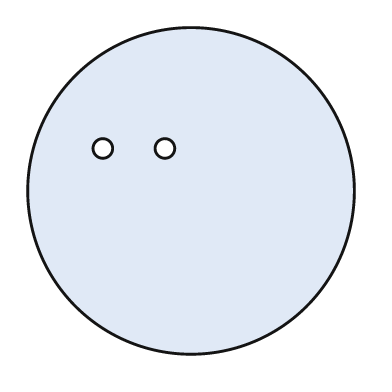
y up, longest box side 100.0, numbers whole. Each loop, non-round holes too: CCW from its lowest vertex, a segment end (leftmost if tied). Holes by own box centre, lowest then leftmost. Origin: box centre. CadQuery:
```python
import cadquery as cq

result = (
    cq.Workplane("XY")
    .moveTo(0.0, 0.0)
    .circle(50.0)
    .moveTo(-27.0, 13.0)
    .circle(3.0)
    .moveTo(-8.0, 13.0)
    .circle(3.0)
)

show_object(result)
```